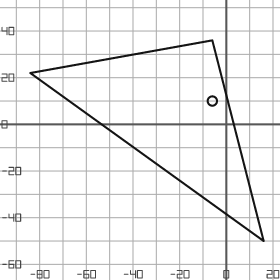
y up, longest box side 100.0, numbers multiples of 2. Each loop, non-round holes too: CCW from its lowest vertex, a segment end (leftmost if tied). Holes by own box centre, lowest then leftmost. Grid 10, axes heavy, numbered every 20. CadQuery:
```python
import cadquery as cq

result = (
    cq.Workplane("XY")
    .moveTo(16.0, -50.0)
    .lineTo(-6.0, 36.0)
    .lineTo(-84.0, 22.0)
    .close()
    .moveTo(-6.0, 10.0)
    .circle(2.0)
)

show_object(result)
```